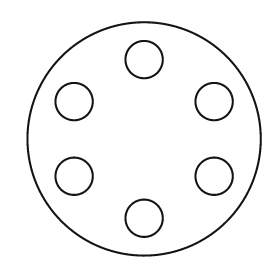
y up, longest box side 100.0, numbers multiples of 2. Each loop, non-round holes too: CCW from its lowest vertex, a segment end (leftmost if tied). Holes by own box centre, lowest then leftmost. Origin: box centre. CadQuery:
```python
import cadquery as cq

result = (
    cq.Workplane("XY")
    .moveTo(0.0, 0.0)
    .circle(50.0)
    .moveTo(0.0, -34.0)
    .circle(8.0)
    .moveTo(-30.0, -16.0)
    .circle(8.0)
    .moveTo(30.0, -16.0)
    .circle(8.0)
    .moveTo(-30.0, 16.0)
    .circle(8.0)
    .moveTo(30.0, 16.0)
    .circle(8.0)
    .moveTo(0.0, 34.0)
    .circle(8.0)
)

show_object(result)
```